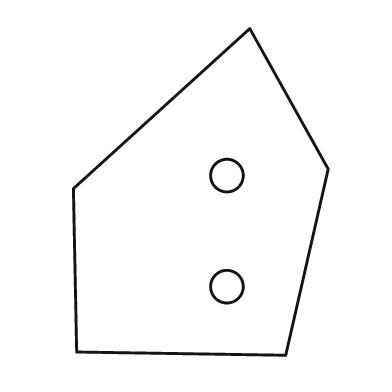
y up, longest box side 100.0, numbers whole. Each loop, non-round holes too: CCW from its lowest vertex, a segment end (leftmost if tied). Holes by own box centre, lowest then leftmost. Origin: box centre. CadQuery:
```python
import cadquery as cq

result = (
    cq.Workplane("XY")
    .moveTo(26.0, -50.0)
    .lineTo(39.0, 7.0)
    .lineTo(15.0, 50.0)
    .lineTo(-39.0, 1.0)
    .lineTo(-38.0, -49.0)
    .close()
    .moveTo(8.0, -29.0)
    .circle(5.0)
    .moveTo(8.0, 5.0)
    .circle(5.0)
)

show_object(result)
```